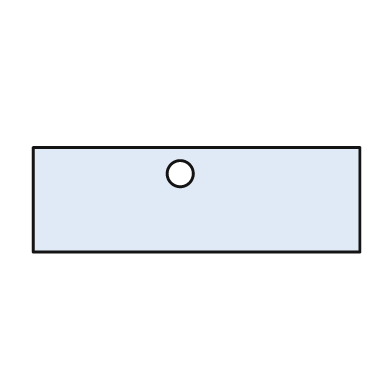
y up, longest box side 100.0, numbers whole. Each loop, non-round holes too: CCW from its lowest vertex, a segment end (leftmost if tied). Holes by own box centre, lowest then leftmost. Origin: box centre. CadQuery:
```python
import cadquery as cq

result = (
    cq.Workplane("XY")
    .moveTo(-50.0, -16.0)
    .lineTo(50.0, -16.0)
    .lineTo(50.0, 16.0)
    .lineTo(-50.0, 16.0)
    .close()
    .moveTo(-5.0, 8.0)
    .circle(4.0)
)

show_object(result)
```